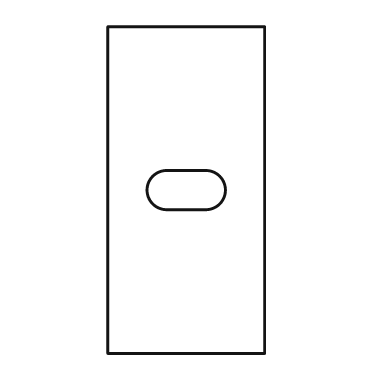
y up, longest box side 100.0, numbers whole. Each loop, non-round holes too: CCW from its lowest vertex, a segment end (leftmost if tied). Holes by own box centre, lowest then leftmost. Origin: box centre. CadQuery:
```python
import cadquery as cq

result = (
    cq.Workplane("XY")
    .moveTo(-24.0, -50.0)
    .lineTo(24.0, -50.0)
    .lineTo(24.0, 50.0)
    .lineTo(-24.0, 50.0)
    .close()
    .moveTo(-6.0, -6.0)
    .lineTo(6.0, -6.0)
    .threePointArc((12.0, 0.0), (6.0, 6.0))
    .lineTo(-6.0, 6.0)
    .threePointArc((-12.0, 0.0), (-6.0, -6.0))
    .close()
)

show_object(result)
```